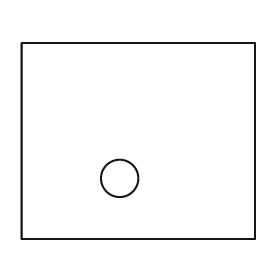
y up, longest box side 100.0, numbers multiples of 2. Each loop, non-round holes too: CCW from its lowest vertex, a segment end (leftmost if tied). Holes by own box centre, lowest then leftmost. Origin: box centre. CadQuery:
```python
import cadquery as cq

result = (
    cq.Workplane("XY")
    .moveTo(-50.0, -42.0)
    .lineTo(50.0, -42.0)
    .lineTo(50.0, 42.0)
    .lineTo(-50.0, 42.0)
    .close()
    .moveTo(-8.0, -16.0)
    .circle(8.0)
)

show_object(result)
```